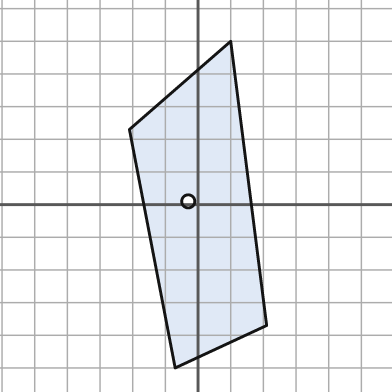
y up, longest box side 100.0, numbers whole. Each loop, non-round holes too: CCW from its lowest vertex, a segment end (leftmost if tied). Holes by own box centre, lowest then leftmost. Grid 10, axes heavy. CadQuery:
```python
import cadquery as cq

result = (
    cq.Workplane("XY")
    .moveTo(-7.0, -50.0)
    .lineTo(21.0, -37.0)
    .lineTo(10.0, 50.0)
    .lineTo(-21.0, 23.0)
    .close()
    .moveTo(-3.0, 1.0)
    .circle(2.0)
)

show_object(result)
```